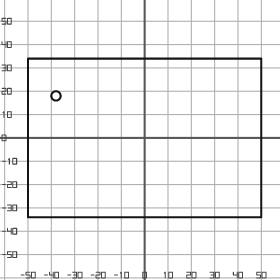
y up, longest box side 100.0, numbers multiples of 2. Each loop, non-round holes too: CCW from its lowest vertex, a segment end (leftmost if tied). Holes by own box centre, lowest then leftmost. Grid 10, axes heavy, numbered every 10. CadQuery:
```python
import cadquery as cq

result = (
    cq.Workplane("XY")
    .moveTo(-50.0, -34.0)
    .lineTo(50.0, -34.0)
    .lineTo(50.0, 34.0)
    .lineTo(-50.0, 34.0)
    .close()
    .moveTo(-38.0, 18.0)
    .circle(2.0)
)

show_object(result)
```